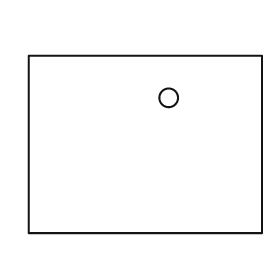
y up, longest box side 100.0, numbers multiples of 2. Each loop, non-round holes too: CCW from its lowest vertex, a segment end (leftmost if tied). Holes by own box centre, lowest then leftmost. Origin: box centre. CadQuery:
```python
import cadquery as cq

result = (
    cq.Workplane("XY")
    .moveTo(-50.0, -38.0)
    .lineTo(50.0, -38.0)
    .lineTo(50.0, 38.0)
    .lineTo(-50.0, 38.0)
    .close()
    .moveTo(10.0, 20.0)
    .circle(4.0)
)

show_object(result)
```